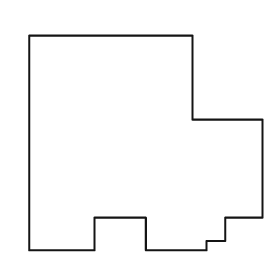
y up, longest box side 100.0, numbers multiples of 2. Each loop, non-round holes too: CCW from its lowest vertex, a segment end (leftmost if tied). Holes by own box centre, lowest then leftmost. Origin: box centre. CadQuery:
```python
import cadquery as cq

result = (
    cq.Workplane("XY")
    .moveTo(-50.0, -46.0)
    .lineTo(-22.0, -46.0)
    .lineTo(-22.0, -32.0)
    .lineTo(0.0, -32.0)
    .lineTo(0.0, -46.0)
    .lineTo(26.0, -46.0)
    .lineTo(26.0, -42.0)
    .lineTo(34.0, -42.0)
    .lineTo(34.0, -32.0)
    .lineTo(50.0, -32.0)
    .lineTo(50.0, 10.0)
    .lineTo(20.0, 10.0)
    .lineTo(20.0, 46.0)
    .lineTo(-50.0, 46.0)
    .close()
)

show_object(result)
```